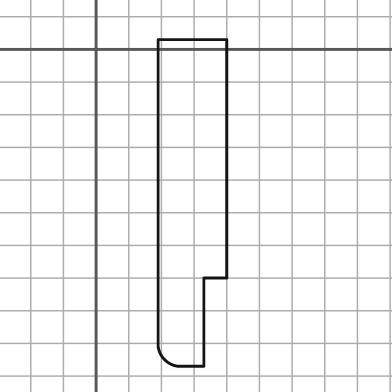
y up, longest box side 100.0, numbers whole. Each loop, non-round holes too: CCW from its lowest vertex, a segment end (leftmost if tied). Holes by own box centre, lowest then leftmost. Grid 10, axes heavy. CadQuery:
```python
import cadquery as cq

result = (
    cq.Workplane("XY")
    .moveTo(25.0, -97.0)
    .lineTo(33.0, -97.0)
    .lineTo(33.0, -70.0)
    .lineTo(40.0, -70.0)
    .lineTo(40.0, 3.0)
    .lineTo(19.0, 3.0)
    .lineTo(19.0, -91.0)
    .threePointArc((21.0, -95.0), (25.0, -97.0))
    .close()
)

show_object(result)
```